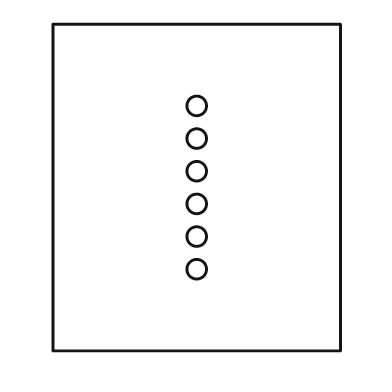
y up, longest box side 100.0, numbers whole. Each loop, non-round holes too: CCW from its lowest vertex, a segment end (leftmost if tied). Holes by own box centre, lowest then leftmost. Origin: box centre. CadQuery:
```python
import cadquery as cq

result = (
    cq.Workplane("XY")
    .moveTo(-44.0, -50.0)
    .lineTo(44.0, -50.0)
    .lineTo(44.0, 50.0)
    .lineTo(-44.0, 50.0)
    .close()
    .moveTo(0.0, -25.0)
    .circle(3.0)
    .moveTo(0.0, -15.0)
    .circle(3.0)
    .moveTo(0.0, -5.0)
    .circle(3.0)
    .moveTo(0.0, 5.0)
    .circle(3.0)
    .moveTo(0.0, 15.0)
    .circle(3.0)
    .moveTo(0.0, 25.0)
    .circle(3.0)
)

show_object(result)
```